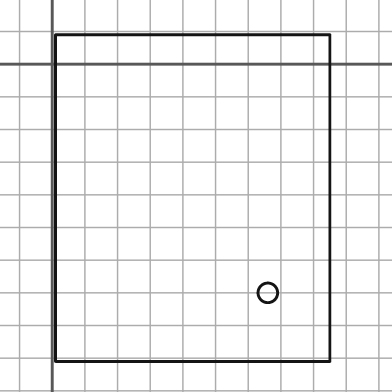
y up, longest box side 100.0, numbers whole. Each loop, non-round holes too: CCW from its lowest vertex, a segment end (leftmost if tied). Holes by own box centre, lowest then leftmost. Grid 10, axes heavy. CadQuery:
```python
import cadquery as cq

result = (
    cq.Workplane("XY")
    .moveTo(1.0, -91.0)
    .lineTo(85.0, -91.0)
    .lineTo(85.0, 9.0)
    .lineTo(1.0, 9.0)
    .close()
    .moveTo(66.0, -70.0)
    .circle(3.0)
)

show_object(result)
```